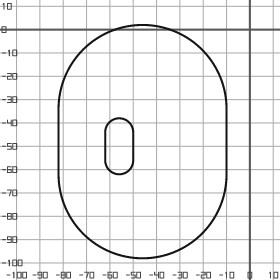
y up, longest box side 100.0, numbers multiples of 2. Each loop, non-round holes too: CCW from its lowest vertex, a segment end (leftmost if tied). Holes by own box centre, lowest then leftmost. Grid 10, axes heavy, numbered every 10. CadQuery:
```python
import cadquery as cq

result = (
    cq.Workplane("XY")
    .moveTo(-82.0, -62.0)
    .threePointArc((-46.0, -98.0), (-10.0, -62.0))
    .lineTo(-10.0, -34.0)
    .threePointArc((-46.0, 2.0), (-82.0, -34.0))
    .close()
    .moveTo(-62.0, -56.0)
    .threePointArc((-56.0, -62.0), (-50.0, -56.0))
    .lineTo(-50.0, -44.0)
    .threePointArc((-56.0, -38.0), (-62.0, -44.0))
    .close()
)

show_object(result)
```